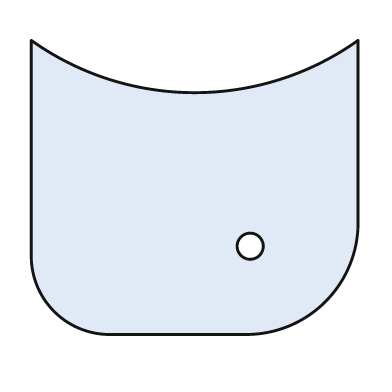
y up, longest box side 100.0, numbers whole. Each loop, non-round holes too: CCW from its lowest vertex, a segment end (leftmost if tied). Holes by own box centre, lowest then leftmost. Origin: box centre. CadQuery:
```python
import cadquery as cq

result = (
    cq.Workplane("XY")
    .moveTo(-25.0, -45.0)
    .lineTo(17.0, -45.0)
    .threePointArc((40.0, -35.0), (50.0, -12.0))
    .lineTo(50.0, 45.0)
    .threePointArc((0.0, 29.0), (-50.0, 45.0))
    .lineTo(-50.0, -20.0)
    .threePointArc((-43.0, -38.0), (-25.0, -45.0))
    .close()
    .moveTo(17.0, -18.0)
    .circle(4.0)
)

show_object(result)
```